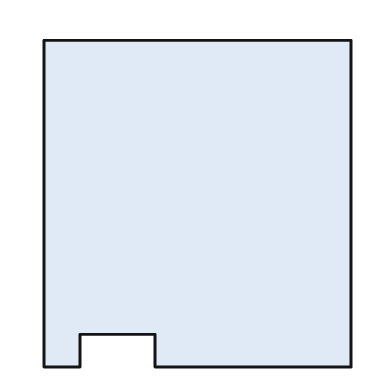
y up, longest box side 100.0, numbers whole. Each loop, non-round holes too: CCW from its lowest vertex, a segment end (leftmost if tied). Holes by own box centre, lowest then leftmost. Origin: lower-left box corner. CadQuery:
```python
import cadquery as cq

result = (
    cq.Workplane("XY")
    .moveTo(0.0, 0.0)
    .lineTo(11.0, 0.0)
    .lineTo(11.0, 10.0)
    .lineTo(34.0, 10.0)
    .lineTo(34.0, 0.0)
    .lineTo(94.0, 0.0)
    .lineTo(94.0, 100.0)
    .lineTo(0.0, 100.0)
    .close()
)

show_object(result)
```